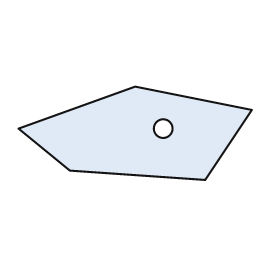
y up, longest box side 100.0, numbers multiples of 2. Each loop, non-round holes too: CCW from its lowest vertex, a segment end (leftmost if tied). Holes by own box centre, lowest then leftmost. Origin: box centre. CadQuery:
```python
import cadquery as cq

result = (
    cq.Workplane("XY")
    .moveTo(30.0, -20.0)
    .lineTo(50.0, 10.0)
    .lineTo(0.0, 20.0)
    .lineTo(-50.0, 2.0)
    .lineTo(-28.0, -16.0)
    .close()
    .moveTo(12.0, 2.0)
    .circle(4.0)
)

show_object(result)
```